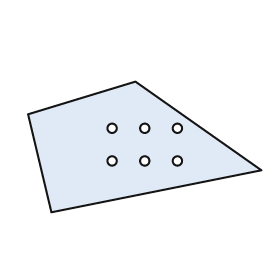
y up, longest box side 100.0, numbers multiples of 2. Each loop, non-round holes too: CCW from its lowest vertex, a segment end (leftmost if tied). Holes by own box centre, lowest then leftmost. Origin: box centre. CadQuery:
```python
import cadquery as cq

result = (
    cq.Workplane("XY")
    .moveTo(-40.0, -28.0)
    .lineTo(50.0, -10.0)
    .lineTo(-4.0, 28.0)
    .lineTo(-50.0, 14.0)
    .close()
    .moveTo(-14.0, -6.0)
    .circle(2.0)
    .moveTo(0.0, -6.0)
    .circle(2.0)
    .moveTo(14.0, -6.0)
    .circle(2.0)
    .moveTo(-14.0, 8.0)
    .circle(2.0)
    .moveTo(0.0, 8.0)
    .circle(2.0)
    .moveTo(14.0, 8.0)
    .circle(2.0)
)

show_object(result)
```